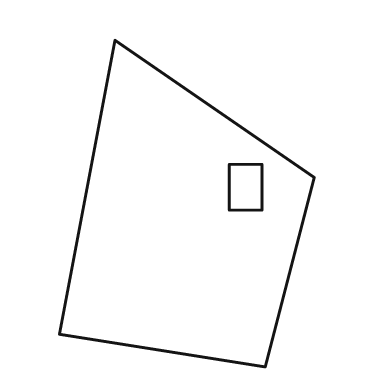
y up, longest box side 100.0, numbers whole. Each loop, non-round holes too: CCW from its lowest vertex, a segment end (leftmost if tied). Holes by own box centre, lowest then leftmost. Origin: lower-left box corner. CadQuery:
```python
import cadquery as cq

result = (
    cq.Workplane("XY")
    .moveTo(63.0, 0.0)
    .lineTo(78.0, 58.0)
    .lineTo(17.0, 100.0)
    .lineTo(0.0, 10.0)
    .close()
    .moveTo(52.0, 48.0)
    .lineTo(62.0, 48.0)
    .lineTo(62.0, 62.0)
    .lineTo(52.0, 62.0)
    .close()
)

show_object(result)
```